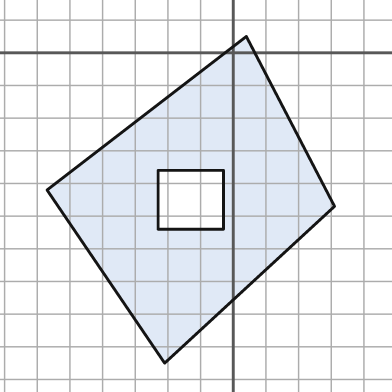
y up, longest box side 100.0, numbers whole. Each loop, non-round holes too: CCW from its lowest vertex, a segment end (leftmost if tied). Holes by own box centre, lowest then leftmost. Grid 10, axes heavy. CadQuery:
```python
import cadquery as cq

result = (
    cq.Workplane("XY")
    .moveTo(-21.0, -95.0)
    .lineTo(31.0, -47.0)
    .lineTo(4.0, 5.0)
    .lineTo(-57.0, -42.0)
    .close()
    .moveTo(-23.0, -54.0)
    .lineTo(-3.0, -54.0)
    .lineTo(-3.0, -36.0)
    .lineTo(-23.0, -36.0)
    .close()
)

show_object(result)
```